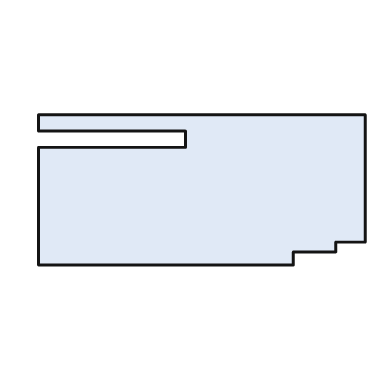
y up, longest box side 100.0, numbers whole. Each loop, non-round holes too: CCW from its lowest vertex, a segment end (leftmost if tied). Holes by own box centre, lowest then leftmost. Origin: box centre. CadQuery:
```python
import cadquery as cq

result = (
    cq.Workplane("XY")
    .moveTo(-50.0, -23.0)
    .lineTo(28.0, -23.0)
    .lineTo(28.0, -19.0)
    .lineTo(41.0, -19.0)
    .lineTo(41.0, -16.0)
    .lineTo(50.0, -16.0)
    .lineTo(50.0, 23.0)
    .lineTo(-50.0, 23.0)
    .lineTo(-50.0, 18.0)
    .lineTo(-5.0, 18.0)
    .lineTo(-5.0, 13.0)
    .lineTo(-50.0, 13.0)
    .close()
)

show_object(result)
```